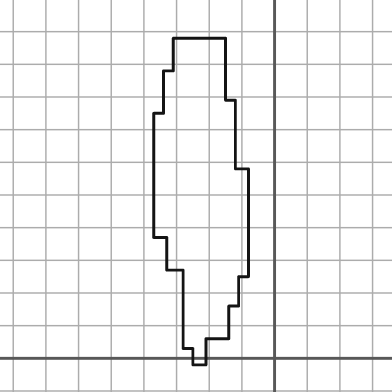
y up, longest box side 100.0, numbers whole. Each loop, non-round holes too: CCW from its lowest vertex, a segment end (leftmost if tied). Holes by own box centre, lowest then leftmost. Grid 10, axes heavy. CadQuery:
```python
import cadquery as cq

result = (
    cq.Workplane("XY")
    .moveTo(-25.0, -2.0)
    .lineTo(-21.0, -2.0)
    .lineTo(-21.0, 6.0)
    .lineTo(-14.0, 6.0)
    .lineTo(-14.0, 16.0)
    .lineTo(-11.0, 16.0)
    .lineTo(-11.0, 25.0)
    .lineTo(-8.0, 25.0)
    .lineTo(-8.0, 58.0)
    .lineTo(-12.0, 58.0)
    .lineTo(-12.0, 79.0)
    .lineTo(-15.0, 79.0)
    .lineTo(-15.0, 98.0)
    .lineTo(-31.0, 98.0)
    .lineTo(-31.0, 88.0)
    .lineTo(-34.0, 88.0)
    .lineTo(-34.0, 75.0)
    .lineTo(-37.0, 75.0)
    .lineTo(-37.0, 37.0)
    .lineTo(-33.0, 37.0)
    .lineTo(-33.0, 27.0)
    .lineTo(-28.0, 27.0)
    .lineTo(-28.0, 3.0)
    .lineTo(-25.0, 3.0)
    .close()
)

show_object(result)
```